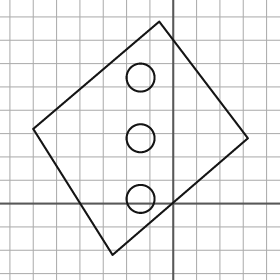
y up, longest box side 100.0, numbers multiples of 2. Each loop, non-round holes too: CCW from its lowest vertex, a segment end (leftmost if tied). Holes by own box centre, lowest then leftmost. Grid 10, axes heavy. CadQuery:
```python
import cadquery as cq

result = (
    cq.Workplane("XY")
    .moveTo(-26.0, -22.0)
    .lineTo(32.0, 28.0)
    .lineTo(-6.0, 78.0)
    .lineTo(-60.0, 32.0)
    .close()
    .moveTo(-14.0, 2.0)
    .circle(6.0)
    .moveTo(-14.0, 28.0)
    .circle(6.0)
    .moveTo(-14.0, 54.0)
    .circle(6.0)
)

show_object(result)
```